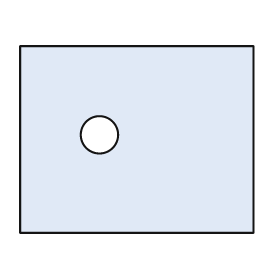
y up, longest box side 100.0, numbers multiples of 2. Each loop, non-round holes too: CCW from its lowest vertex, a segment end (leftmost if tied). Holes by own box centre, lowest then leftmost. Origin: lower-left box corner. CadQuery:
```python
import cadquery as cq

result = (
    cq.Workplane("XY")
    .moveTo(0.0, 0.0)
    .lineTo(100.0, 0.0)
    .lineTo(100.0, 80.0)
    .lineTo(0.0, 80.0)
    .close()
    .moveTo(34.0, 42.0)
    .circle(8.0)
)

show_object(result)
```